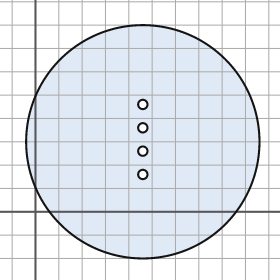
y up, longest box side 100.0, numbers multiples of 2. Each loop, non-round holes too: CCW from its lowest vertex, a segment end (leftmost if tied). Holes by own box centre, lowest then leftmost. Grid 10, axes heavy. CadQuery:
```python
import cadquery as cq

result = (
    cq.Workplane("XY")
    .moveTo(46.0, 30.0)
    .circle(50.0)
    .moveTo(46.0, 16.0)
    .circle(2.0)
    .moveTo(46.0, 26.0)
    .circle(2.0)
    .moveTo(46.0, 36.0)
    .circle(2.0)
    .moveTo(46.0, 46.0)
    .circle(2.0)
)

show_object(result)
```